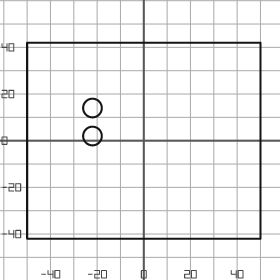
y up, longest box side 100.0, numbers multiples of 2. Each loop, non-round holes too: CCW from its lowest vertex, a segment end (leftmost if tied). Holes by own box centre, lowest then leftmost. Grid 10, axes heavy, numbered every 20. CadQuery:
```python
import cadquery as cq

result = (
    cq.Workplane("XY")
    .moveTo(-50.0, -42.0)
    .lineTo(50.0, -42.0)
    .lineTo(50.0, 42.0)
    .lineTo(-50.0, 42.0)
    .close()
    .moveTo(-22.0, 2.0)
    .circle(4.0)
    .moveTo(-22.0, 14.0)
    .circle(4.0)
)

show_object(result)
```